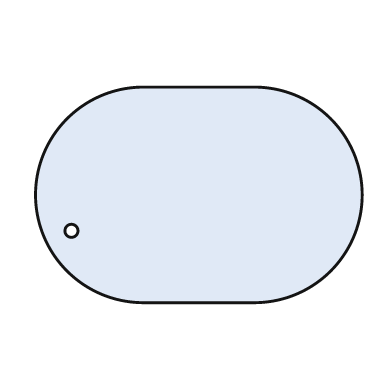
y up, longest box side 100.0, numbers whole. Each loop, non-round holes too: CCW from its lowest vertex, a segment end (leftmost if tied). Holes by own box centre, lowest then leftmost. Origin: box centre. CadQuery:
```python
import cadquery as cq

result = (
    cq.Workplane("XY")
    .moveTo(-17.0, -33.0)
    .lineTo(17.0, -33.0)
    .threePointArc((50.0, 0.0), (17.0, 33.0))
    .lineTo(-17.0, 33.0)
    .threePointArc((-50.0, 0.0), (-17.0, -33.0))
    .close()
    .moveTo(-39.0, -11.0)
    .circle(2.0)
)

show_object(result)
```